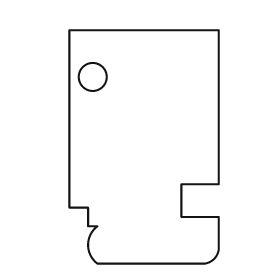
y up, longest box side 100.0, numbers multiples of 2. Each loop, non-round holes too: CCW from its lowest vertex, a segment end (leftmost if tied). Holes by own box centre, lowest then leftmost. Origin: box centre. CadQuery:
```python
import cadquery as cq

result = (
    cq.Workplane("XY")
    .moveTo(-20.0, -50.0)
    .lineTo(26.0, -50.0)
    .threePointArc((30.0, -48.0), (32.0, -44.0))
    .lineTo(32.0, -30.0)
    .lineTo(16.0, -30.0)
    .lineTo(16.0, -16.0)
    .lineTo(32.0, -16.0)
    .lineTo(32.0, 50.0)
    .lineTo(-32.0, 50.0)
    .lineTo(-32.0, -26.0)
    .lineTo(-24.0, -26.0)
    .lineTo(-24.0, -34.0)
    .lineTo(-20.0, -34.0)
    .threePointArc((-24.0, -42.0), (-20.0, -50.0))
    .close()
    .moveTo(-22.0, 30.0)
    .circle(6.0)
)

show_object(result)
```